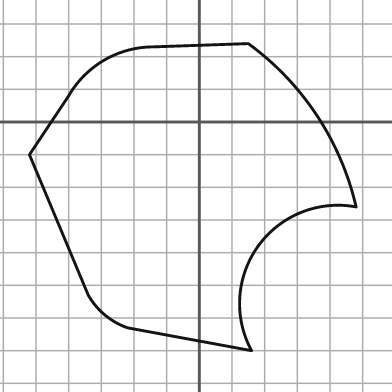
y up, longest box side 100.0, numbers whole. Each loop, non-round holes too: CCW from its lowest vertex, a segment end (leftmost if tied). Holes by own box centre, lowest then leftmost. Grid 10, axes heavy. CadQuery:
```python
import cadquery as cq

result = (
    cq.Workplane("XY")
    .moveTo(16.0, -70.0)
    .threePointArc((18.0, -38.0), (48.0, -26.0))
    .threePointArc((36.0, 2.0), (15.0, 24.0))
    .lineTo(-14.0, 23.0)
    .threePointArc((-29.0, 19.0), (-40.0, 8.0))
    .lineTo(-52.0, -10.0)
    .lineTo(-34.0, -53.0)
    .threePointArc((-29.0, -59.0), (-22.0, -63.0))
    .close()
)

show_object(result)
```